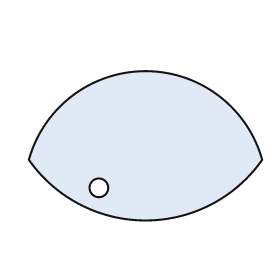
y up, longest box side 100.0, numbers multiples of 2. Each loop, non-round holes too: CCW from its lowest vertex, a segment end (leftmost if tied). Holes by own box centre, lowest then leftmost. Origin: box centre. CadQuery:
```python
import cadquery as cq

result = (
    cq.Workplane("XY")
    .moveTo(-50.0, -6.0)
    .threePointArc((0.0, -32.0), (50.0, -6.0))
    .threePointArc((0.0, 32.0), (-50.0, -6.0))
    .close()
    .moveTo(-20.0, -18.0)
    .circle(4.0)
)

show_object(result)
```